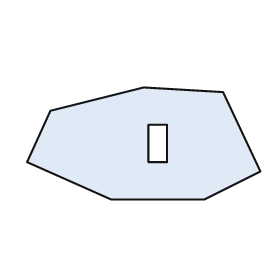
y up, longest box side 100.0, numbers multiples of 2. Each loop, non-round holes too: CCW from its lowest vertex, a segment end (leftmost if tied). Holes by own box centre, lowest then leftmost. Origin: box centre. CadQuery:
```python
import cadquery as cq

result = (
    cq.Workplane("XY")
    .moveTo(-14.0, -24.0)
    .lineTo(26.0, -24.0)
    .lineTo(50.0, -12.0)
    .lineTo(34.0, 22.0)
    .lineTo(0.0, 24.0)
    .lineTo(-40.0, 14.0)
    .lineTo(-50.0, -8.0)
    .close()
    .moveTo(2.0, -8.0)
    .lineTo(10.0, -8.0)
    .lineTo(10.0, 8.0)
    .lineTo(2.0, 8.0)
    .close()
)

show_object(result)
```